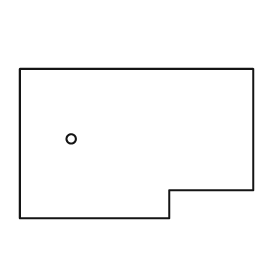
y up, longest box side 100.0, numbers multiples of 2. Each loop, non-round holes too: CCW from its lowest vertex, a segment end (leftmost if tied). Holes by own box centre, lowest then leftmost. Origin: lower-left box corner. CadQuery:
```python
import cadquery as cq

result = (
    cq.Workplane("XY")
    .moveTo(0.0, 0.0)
    .lineTo(64.0, 0.0)
    .lineTo(64.0, 12.0)
    .lineTo(100.0, 12.0)
    .lineTo(100.0, 64.0)
    .lineTo(0.0, 64.0)
    .close()
    .moveTo(22.0, 34.0)
    .circle(2.0)
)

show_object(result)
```